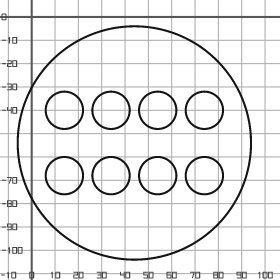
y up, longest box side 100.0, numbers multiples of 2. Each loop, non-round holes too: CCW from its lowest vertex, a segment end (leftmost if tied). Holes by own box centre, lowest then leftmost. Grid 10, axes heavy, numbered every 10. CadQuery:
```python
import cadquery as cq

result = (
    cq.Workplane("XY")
    .moveTo(44.0, -54.0)
    .circle(50.0)
    .moveTo(14.0, -68.0)
    .circle(8.0)
    .moveTo(34.0, -68.0)
    .circle(8.0)
    .moveTo(54.0, -68.0)
    .circle(8.0)
    .moveTo(74.0, -68.0)
    .circle(8.0)
    .moveTo(14.0, -40.0)
    .circle(8.0)
    .moveTo(34.0, -40.0)
    .circle(8.0)
    .moveTo(54.0, -40.0)
    .circle(8.0)
    .moveTo(74.0, -40.0)
    .circle(8.0)
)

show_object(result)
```